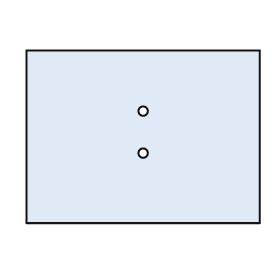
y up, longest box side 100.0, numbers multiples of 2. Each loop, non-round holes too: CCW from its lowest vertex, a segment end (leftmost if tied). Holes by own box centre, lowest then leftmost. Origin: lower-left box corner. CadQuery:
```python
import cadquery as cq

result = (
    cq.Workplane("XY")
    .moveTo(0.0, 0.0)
    .lineTo(100.0, 0.0)
    .lineTo(100.0, 74.0)
    .lineTo(0.0, 74.0)
    .close()
    .moveTo(50.0, 30.0)
    .circle(2.0)
    .moveTo(50.0, 48.0)
    .circle(2.0)
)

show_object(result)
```